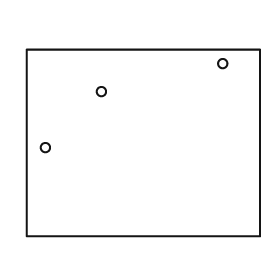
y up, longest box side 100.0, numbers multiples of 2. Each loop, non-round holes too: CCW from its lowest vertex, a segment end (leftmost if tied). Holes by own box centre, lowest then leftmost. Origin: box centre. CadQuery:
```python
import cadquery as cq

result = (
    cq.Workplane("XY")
    .moveTo(-50.0, -40.0)
    .lineTo(50.0, -40.0)
    .lineTo(50.0, 40.0)
    .lineTo(-50.0, 40.0)
    .close()
    .moveTo(-42.0, -2.0)
    .circle(2.0)
    .moveTo(-18.0, 22.0)
    .circle(2.0)
    .moveTo(34.0, 34.0)
    .circle(2.0)
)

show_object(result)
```